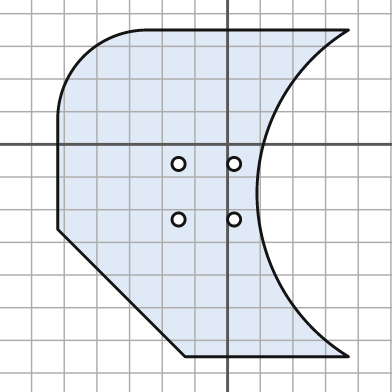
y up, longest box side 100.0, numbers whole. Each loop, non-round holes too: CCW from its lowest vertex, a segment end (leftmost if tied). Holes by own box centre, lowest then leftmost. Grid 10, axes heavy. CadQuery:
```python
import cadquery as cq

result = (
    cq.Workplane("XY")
    .moveTo(-13.0, -65.0)
    .lineTo(37.0, -65.0)
    .threePointArc((9.0, -15.0), (37.0, 35.0))
    .lineTo(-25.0, 35.0)
    .threePointArc((-44.0, 27.0), (-52.0, 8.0))
    .lineTo(-52.0, -26.0)
    .close()
    .moveTo(-15.0, -23.0)
    .circle(2.0)
    .moveTo(2.0, -23.0)
    .circle(2.0)
    .moveTo(-15.0, -6.0)
    .circle(2.0)
    .moveTo(2.0, -6.0)
    .circle(2.0)
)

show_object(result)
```